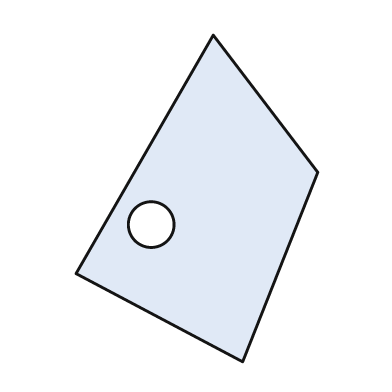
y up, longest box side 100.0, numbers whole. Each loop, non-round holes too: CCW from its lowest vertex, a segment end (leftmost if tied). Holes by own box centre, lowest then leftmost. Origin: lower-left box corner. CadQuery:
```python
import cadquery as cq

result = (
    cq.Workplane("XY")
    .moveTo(51.0, 0.0)
    .lineTo(74.0, 58.0)
    .lineTo(42.0, 100.0)
    .lineTo(0.0, 27.0)
    .close()
    .moveTo(23.0, 42.0)
    .circle(7.0)
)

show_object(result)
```